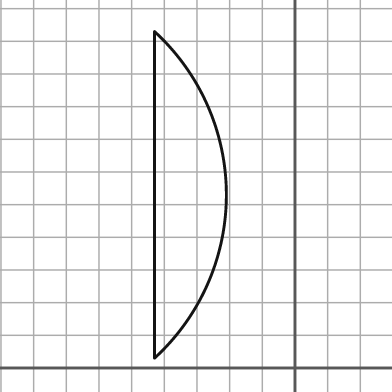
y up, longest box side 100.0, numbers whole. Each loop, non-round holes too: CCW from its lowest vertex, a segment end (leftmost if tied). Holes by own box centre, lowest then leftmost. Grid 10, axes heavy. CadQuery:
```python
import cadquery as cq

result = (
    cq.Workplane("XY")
    .moveTo(-43.0, 3.0)
    .threePointArc((-21.0, 53.0), (-43.0, 103.0))
    .close()
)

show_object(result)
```